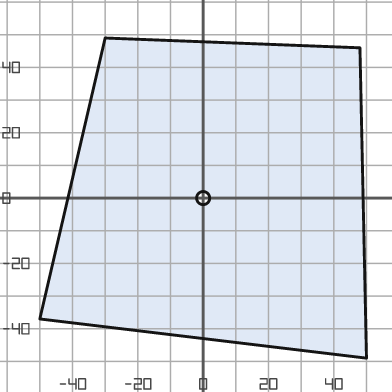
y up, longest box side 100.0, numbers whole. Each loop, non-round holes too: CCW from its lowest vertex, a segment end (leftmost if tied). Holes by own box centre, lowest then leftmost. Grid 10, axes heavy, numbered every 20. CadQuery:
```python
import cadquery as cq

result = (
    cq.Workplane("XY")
    .moveTo(50.0, -49.0)
    .lineTo(48.0, 46.0)
    .lineTo(-30.0, 49.0)
    .lineTo(-50.0, -37.0)
    .close()
    .moveTo(0.0, 0.0)
    .circle(2.0)
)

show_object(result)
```